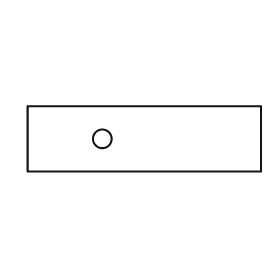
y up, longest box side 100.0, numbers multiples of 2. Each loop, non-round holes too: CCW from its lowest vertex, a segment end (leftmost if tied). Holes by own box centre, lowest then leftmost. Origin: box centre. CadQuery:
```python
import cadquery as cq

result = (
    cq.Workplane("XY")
    .moveTo(-50.0, -14.0)
    .lineTo(50.0, -14.0)
    .lineTo(50.0, 14.0)
    .lineTo(-50.0, 14.0)
    .close()
    .moveTo(-18.0, 0.0)
    .circle(4.0)
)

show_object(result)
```